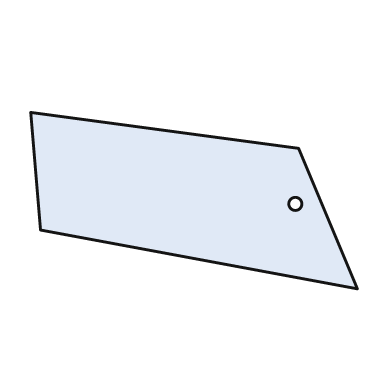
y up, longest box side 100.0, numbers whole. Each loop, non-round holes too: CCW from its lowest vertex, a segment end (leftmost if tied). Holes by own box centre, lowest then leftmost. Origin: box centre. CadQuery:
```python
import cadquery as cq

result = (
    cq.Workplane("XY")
    .moveTo(50.0, -27.0)
    .lineTo(32.0, 16.0)
    .lineTo(-50.0, 27.0)
    .lineTo(-47.0, -9.0)
    .close()
    .moveTo(31.0, -1.0)
    .circle(2.0)
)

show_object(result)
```